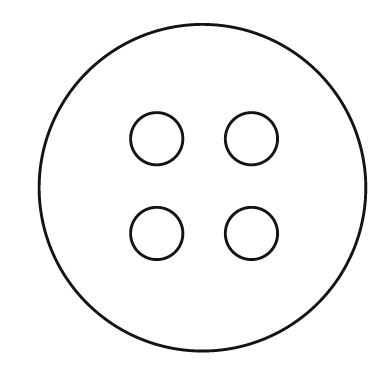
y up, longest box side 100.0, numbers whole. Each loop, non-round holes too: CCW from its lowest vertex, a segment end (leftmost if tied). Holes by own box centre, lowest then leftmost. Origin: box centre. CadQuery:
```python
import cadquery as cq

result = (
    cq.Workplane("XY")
    .moveTo(0.0, 0.0)
    .circle(50.0)
    .moveTo(-14.0, -14.0)
    .circle(8.0)
    .moveTo(15.0, -14.0)
    .circle(8.0)
    .moveTo(-14.0, 15.0)
    .circle(8.0)
    .moveTo(15.0, 15.0)
    .circle(8.0)
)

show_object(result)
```